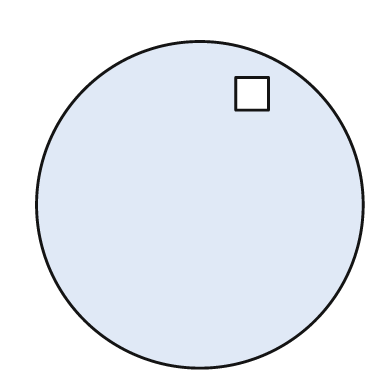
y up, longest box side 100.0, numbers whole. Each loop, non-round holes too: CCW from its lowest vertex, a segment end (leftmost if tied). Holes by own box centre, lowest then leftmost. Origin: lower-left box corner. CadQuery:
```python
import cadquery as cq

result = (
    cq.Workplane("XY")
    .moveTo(50.0, 50.0)
    .circle(50.0)
    .moveTo(61.0, 79.0)
    .lineTo(71.0, 79.0)
    .lineTo(71.0, 89.0)
    .lineTo(61.0, 89.0)
    .close()
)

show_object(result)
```